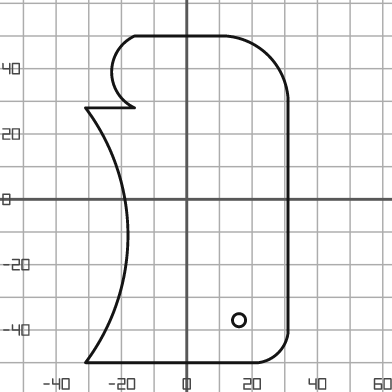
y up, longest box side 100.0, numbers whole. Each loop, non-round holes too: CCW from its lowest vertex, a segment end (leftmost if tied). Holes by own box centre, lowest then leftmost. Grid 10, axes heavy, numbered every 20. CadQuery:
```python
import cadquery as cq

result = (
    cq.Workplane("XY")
    .moveTo(-31.0, -50.0)
    .lineTo(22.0, -50.0)
    .threePointArc((28.0, -47.0), (31.0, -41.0))
    .lineTo(31.0, 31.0)
    .threePointArc((25.0, 44.0), (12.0, 50.0))
    .lineTo(-16.0, 50.0)
    .threePointArc((-23.0, 39.0), (-16.0, 28.0))
    .lineTo(-31.0, 28.0)
    .threePointArc((-18.0, -11.0), (-31.0, -50.0))
    .close()
    .moveTo(16.0, -37.0)
    .circle(2.0)
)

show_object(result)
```